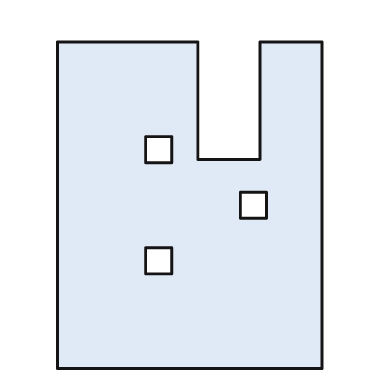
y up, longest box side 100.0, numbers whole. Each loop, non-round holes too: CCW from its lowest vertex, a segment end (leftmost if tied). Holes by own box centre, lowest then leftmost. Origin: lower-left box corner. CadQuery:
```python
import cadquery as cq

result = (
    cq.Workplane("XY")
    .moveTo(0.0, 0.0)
    .lineTo(81.0, 0.0)
    .lineTo(81.0, 100.0)
    .lineTo(62.0, 100.0)
    .lineTo(62.0, 64.0)
    .lineTo(43.0, 64.0)
    .lineTo(43.0, 100.0)
    .lineTo(0.0, 100.0)
    .close()
    .moveTo(27.0, 29.0)
    .lineTo(35.0, 29.0)
    .lineTo(35.0, 37.0)
    .lineTo(27.0, 37.0)
    .close()
    .moveTo(56.0, 46.0)
    .lineTo(64.0, 46.0)
    .lineTo(64.0, 54.0)
    .lineTo(56.0, 54.0)
    .close()
    .moveTo(27.0, 63.0)
    .lineTo(35.0, 63.0)
    .lineTo(35.0, 71.0)
    .lineTo(27.0, 71.0)
    .close()
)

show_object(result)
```